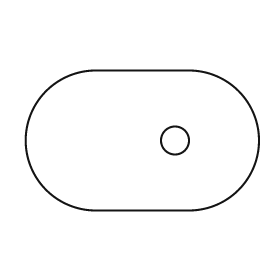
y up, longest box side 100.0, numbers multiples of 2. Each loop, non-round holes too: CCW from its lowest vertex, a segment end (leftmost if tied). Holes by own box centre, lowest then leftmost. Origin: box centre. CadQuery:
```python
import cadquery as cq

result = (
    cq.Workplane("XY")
    .moveTo(-20.0, -30.0)
    .lineTo(20.0, -30.0)
    .threePointArc((50.0, 0.0), (20.0, 30.0))
    .lineTo(-20.0, 30.0)
    .threePointArc((-50.0, 0.0), (-20.0, -30.0))
    .close()
    .moveTo(14.0, 0.0)
    .circle(6.0)
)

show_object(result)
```